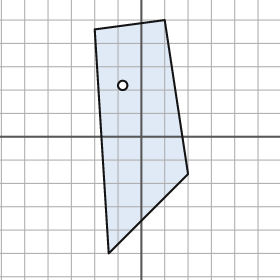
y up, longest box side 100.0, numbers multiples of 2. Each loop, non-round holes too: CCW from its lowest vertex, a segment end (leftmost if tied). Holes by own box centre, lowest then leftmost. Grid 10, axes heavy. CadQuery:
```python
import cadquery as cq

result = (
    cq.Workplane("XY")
    .moveTo(-14.0, -50.0)
    .lineTo(20.0, -16.0)
    .lineTo(10.0, 50.0)
    .lineTo(-20.0, 46.0)
    .close()
    .moveTo(-8.0, 22.0)
    .circle(2.0)
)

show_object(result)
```